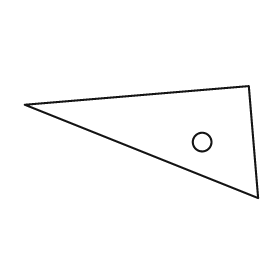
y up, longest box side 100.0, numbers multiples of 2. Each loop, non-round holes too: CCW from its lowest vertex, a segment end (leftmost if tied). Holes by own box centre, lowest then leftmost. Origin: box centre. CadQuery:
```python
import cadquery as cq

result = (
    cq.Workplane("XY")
    .moveTo(50.0, -24.0)
    .lineTo(46.0, 24.0)
    .lineTo(-50.0, 16.0)
    .close()
    .moveTo(26.0, 0.0)
    .circle(4.0)
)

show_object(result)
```